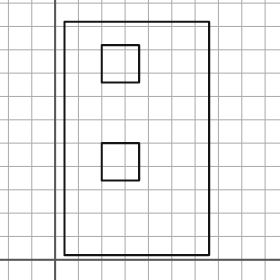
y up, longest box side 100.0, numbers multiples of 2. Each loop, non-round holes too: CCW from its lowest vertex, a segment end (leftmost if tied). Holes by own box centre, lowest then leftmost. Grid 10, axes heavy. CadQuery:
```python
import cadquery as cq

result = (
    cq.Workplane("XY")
    .moveTo(4.0, 2.0)
    .lineTo(66.0, 2.0)
    .lineTo(66.0, 102.0)
    .lineTo(4.0, 102.0)
    .close()
    .moveTo(20.0, 34.0)
    .lineTo(36.0, 34.0)
    .lineTo(36.0, 50.0)
    .lineTo(20.0, 50.0)
    .close()
    .moveTo(20.0, 76.0)
    .lineTo(36.0, 76.0)
    .lineTo(36.0, 92.0)
    .lineTo(20.0, 92.0)
    .close()
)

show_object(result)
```